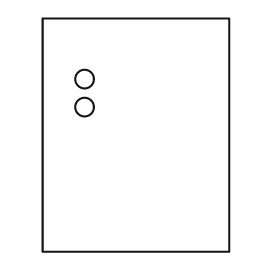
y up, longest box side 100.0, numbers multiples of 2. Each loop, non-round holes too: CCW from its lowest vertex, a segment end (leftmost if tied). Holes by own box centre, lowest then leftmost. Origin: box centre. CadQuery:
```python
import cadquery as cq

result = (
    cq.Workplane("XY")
    .moveTo(-40.0, -50.0)
    .lineTo(40.0, -50.0)
    .lineTo(40.0, 50.0)
    .lineTo(-40.0, 50.0)
    .close()
    .moveTo(-22.0, 12.0)
    .circle(4.0)
    .moveTo(-22.0, 24.0)
    .circle(4.0)
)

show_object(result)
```